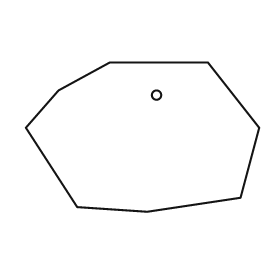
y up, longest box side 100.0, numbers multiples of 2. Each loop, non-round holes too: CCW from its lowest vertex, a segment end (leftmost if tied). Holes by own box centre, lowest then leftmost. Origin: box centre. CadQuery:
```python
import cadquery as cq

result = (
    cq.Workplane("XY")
    .moveTo(2.0, -32.0)
    .lineTo(42.0, -26.0)
    .lineTo(50.0, 4.0)
    .lineTo(28.0, 32.0)
    .lineTo(-14.0, 32.0)
    .lineTo(-36.0, 20.0)
    .lineTo(-50.0, 4.0)
    .lineTo(-28.0, -30.0)
    .close()
    .moveTo(6.0, 18.0)
    .circle(2.0)
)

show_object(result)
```